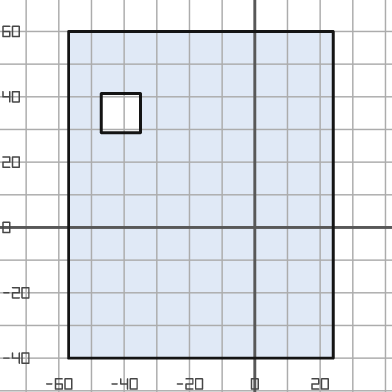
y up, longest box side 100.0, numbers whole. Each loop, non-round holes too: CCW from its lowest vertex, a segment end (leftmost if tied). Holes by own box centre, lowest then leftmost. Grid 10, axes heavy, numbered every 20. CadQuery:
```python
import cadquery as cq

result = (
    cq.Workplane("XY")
    .moveTo(-57.0, -40.0)
    .lineTo(24.0, -40.0)
    .lineTo(24.0, 60.0)
    .lineTo(-57.0, 60.0)
    .close()
    .moveTo(-47.0, 29.0)
    .lineTo(-35.0, 29.0)
    .lineTo(-35.0, 41.0)
    .lineTo(-47.0, 41.0)
    .close()
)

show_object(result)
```